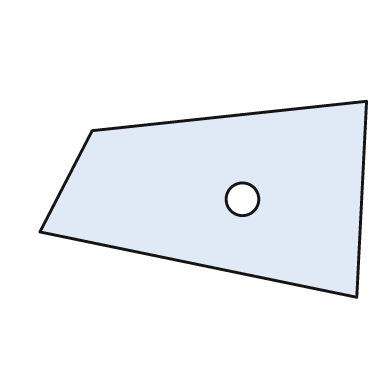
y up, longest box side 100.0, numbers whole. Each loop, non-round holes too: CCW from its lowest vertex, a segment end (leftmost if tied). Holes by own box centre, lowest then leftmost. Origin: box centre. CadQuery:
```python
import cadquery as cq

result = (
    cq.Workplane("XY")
    .moveTo(47.0, -30.0)
    .lineTo(50.0, 30.0)
    .lineTo(-34.0, 21.0)
    .lineTo(-50.0, -10.0)
    .close()
    .moveTo(12.0, 0.0)
    .circle(5.0)
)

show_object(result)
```